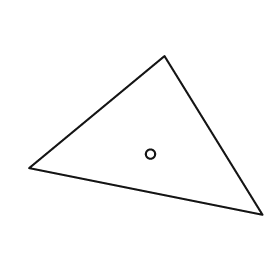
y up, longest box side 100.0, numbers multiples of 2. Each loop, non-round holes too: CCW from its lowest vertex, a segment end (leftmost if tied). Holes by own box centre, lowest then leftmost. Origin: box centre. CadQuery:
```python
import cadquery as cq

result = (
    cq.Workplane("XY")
    .moveTo(50.0, -34.0)
    .lineTo(8.0, 34.0)
    .lineTo(-50.0, -14.0)
    .close()
    .moveTo(2.0, -8.0)
    .circle(2.0)
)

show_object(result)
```